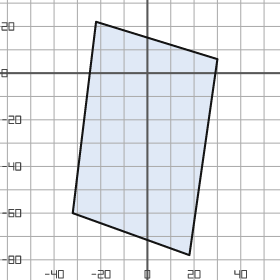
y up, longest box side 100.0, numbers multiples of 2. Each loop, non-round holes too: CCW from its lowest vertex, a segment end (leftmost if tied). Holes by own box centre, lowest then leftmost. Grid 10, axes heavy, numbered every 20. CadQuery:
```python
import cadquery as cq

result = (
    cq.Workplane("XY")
    .moveTo(18.0, -78.0)
    .lineTo(30.0, 6.0)
    .lineTo(-22.0, 22.0)
    .lineTo(-32.0, -60.0)
    .close()
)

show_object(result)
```